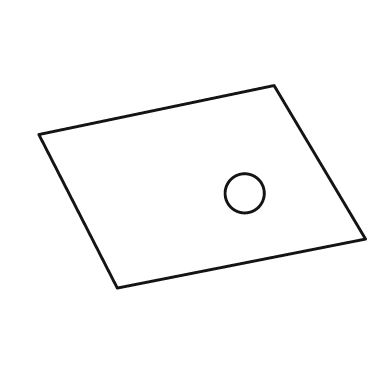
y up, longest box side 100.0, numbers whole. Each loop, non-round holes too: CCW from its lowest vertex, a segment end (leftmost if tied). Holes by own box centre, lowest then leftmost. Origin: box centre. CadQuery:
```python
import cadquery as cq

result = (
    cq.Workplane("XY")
    .moveTo(-26.0, -31.0)
    .lineTo(50.0, -16.0)
    .lineTo(22.0, 31.0)
    .lineTo(-50.0, 16.0)
    .close()
    .moveTo(13.0, -2.0)
    .circle(6.0)
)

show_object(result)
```